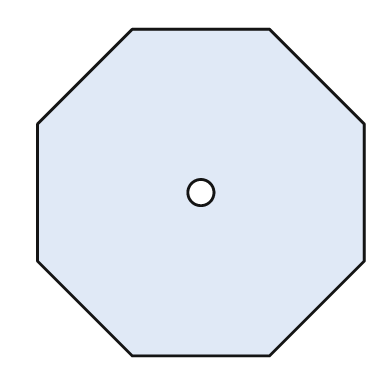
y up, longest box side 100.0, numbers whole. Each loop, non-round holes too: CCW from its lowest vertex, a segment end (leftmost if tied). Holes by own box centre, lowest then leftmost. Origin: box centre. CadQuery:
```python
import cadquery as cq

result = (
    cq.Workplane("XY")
    .moveTo(-21.0, -50.0)
    .lineTo(21.0, -50.0)
    .lineTo(50.0, -21.0)
    .lineTo(50.0, 21.0)
    .lineTo(21.0, 50.0)
    .lineTo(-21.0, 50.0)
    .lineTo(-50.0, 21.0)
    .lineTo(-50.0, -21.0)
    .close()
    .moveTo(0.0, 0.0)
    .circle(4.0)
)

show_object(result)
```